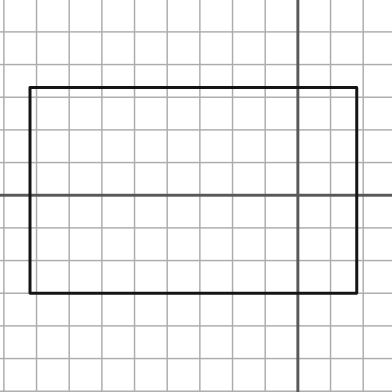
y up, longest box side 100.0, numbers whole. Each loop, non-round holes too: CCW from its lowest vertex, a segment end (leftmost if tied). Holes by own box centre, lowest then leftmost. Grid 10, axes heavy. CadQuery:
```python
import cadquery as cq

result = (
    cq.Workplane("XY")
    .moveTo(-82.0, -30.0)
    .lineTo(18.0, -30.0)
    .lineTo(18.0, 33.0)
    .lineTo(-82.0, 33.0)
    .close()
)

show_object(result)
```